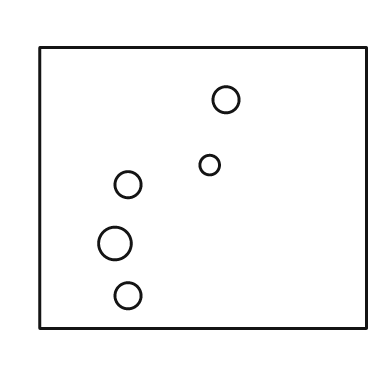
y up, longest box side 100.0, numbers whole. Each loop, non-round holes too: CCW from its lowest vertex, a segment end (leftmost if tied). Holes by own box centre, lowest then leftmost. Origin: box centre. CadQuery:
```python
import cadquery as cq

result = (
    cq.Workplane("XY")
    .moveTo(-50.0, -43.0)
    .lineTo(50.0, -43.0)
    .lineTo(50.0, 43.0)
    .lineTo(-50.0, 43.0)
    .close()
    .moveTo(-23.0, -33.0)
    .circle(4.0)
    .moveTo(-27.0, -17.0)
    .circle(5.0)
    .moveTo(-23.0, 1.0)
    .circle(4.0)
    .moveTo(2.0, 7.0)
    .circle(3.0)
    .moveTo(7.0, 27.0)
    .circle(4.0)
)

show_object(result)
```